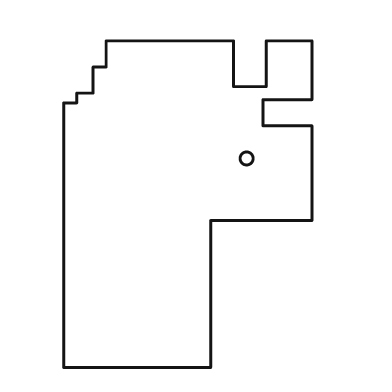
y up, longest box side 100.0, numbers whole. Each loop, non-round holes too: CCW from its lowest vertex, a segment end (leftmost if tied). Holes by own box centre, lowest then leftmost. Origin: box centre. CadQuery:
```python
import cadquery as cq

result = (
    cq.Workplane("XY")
    .moveTo(-38.0, -50.0)
    .lineTo(7.0, -50.0)
    .lineTo(7.0, -5.0)
    .lineTo(38.0, -5.0)
    .lineTo(38.0, 24.0)
    .lineTo(23.0, 24.0)
    .lineTo(23.0, 32.0)
    .lineTo(38.0, 32.0)
    .lineTo(38.0, 50.0)
    .lineTo(24.0, 50.0)
    .lineTo(24.0, 36.0)
    .lineTo(14.0, 36.0)
    .lineTo(14.0, 50.0)
    .lineTo(-25.0, 50.0)
    .lineTo(-25.0, 42.0)
    .lineTo(-29.0, 42.0)
    .lineTo(-29.0, 34.0)
    .lineTo(-34.0, 34.0)
    .lineTo(-34.0, 31.0)
    .lineTo(-38.0, 31.0)
    .close()
    .moveTo(18.0, 14.0)
    .circle(2.0)
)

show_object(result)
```